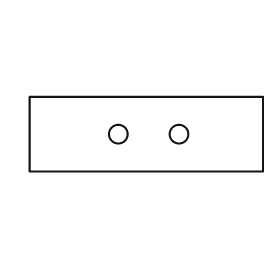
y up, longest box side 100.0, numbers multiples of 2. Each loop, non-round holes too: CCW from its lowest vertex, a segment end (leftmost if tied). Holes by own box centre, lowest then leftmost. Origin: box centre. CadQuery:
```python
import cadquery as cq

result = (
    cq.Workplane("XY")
    .moveTo(-50.0, -16.0)
    .lineTo(50.0, -16.0)
    .lineTo(50.0, 16.0)
    .lineTo(-50.0, 16.0)
    .close()
    .moveTo(-12.0, 0.0)
    .circle(4.0)
    .moveTo(14.0, 0.0)
    .circle(4.0)
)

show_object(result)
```